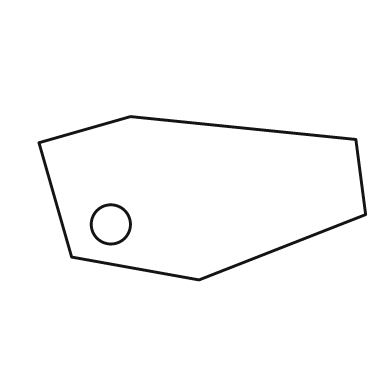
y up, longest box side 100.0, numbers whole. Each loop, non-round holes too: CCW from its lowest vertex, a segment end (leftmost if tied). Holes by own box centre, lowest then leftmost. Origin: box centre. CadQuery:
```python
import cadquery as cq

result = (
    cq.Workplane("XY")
    .moveTo(-1.0, -25.0)
    .lineTo(50.0, -5.0)
    .lineTo(47.0, 18.0)
    .lineTo(-22.0, 25.0)
    .lineTo(-50.0, 17.0)
    .lineTo(-40.0, -18.0)
    .close()
    .moveTo(-28.0, -8.0)
    .circle(6.0)
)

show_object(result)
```